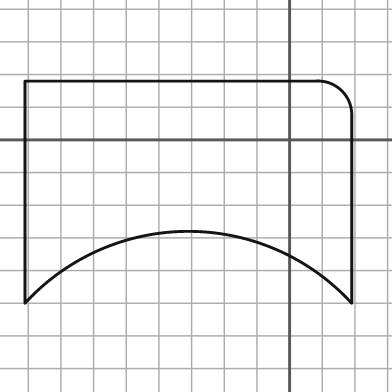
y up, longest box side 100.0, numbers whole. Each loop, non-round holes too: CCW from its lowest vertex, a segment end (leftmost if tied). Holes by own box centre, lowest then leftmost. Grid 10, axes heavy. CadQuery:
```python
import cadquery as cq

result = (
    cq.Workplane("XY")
    .moveTo(-81.0, -50.0)
    .threePointArc((-31.0, -28.0), (19.0, -50.0))
    .lineTo(19.0, 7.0)
    .threePointArc((16.0, 15.0), (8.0, 18.0))
    .lineTo(-81.0, 18.0)
    .close()
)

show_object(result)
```